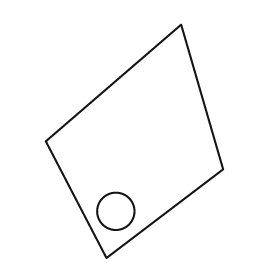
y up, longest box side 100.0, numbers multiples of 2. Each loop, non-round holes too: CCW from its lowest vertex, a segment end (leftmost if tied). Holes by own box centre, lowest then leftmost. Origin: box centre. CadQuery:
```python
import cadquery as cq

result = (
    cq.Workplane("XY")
    .moveTo(-12.0, -50.0)
    .lineTo(38.0, -12.0)
    .lineTo(20.0, 50.0)
    .lineTo(-38.0, 0.0)
    .close()
    .moveTo(-8.0, -30.0)
    .circle(8.0)
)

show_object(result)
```